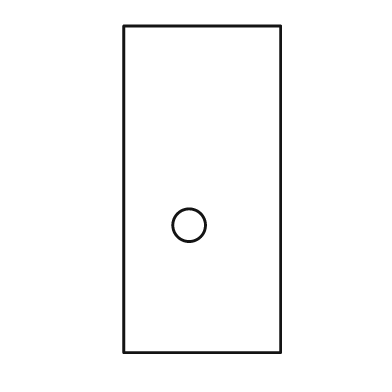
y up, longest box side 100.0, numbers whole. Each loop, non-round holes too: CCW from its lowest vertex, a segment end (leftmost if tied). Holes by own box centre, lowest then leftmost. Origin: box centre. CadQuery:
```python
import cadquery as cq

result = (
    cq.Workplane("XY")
    .moveTo(-24.0, -50.0)
    .lineTo(24.0, -50.0)
    .lineTo(24.0, 50.0)
    .lineTo(-24.0, 50.0)
    .close()
    .moveTo(-4.0, -11.0)
    .circle(5.0)
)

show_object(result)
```